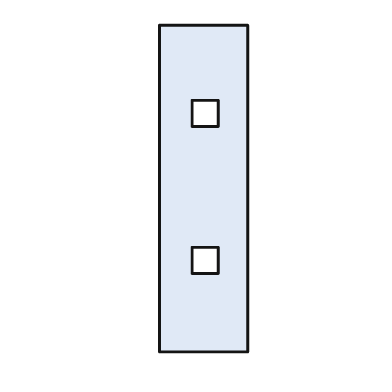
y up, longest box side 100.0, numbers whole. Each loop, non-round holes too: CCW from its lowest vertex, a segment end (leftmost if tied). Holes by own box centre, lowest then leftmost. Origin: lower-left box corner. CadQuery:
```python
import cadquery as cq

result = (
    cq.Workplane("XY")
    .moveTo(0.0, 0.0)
    .lineTo(27.0, 0.0)
    .lineTo(27.0, 100.0)
    .lineTo(0.0, 100.0)
    .close()
    .moveTo(10.0, 24.0)
    .lineTo(18.0, 24.0)
    .lineTo(18.0, 32.0)
    .lineTo(10.0, 32.0)
    .close()
    .moveTo(10.0, 69.0)
    .lineTo(18.0, 69.0)
    .lineTo(18.0, 77.0)
    .lineTo(10.0, 77.0)
    .close()
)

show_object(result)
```